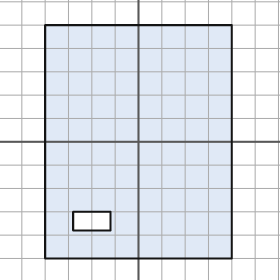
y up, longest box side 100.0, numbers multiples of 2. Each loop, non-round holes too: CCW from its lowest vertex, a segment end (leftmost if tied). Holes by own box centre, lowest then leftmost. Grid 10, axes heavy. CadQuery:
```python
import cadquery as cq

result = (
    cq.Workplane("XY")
    .moveTo(-40.0, -50.0)
    .lineTo(40.0, -50.0)
    .lineTo(40.0, 50.0)
    .lineTo(-40.0, 50.0)
    .close()
    .moveTo(-28.0, -38.0)
    .lineTo(-12.0, -38.0)
    .lineTo(-12.0, -30.0)
    .lineTo(-28.0, -30.0)
    .close()
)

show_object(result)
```